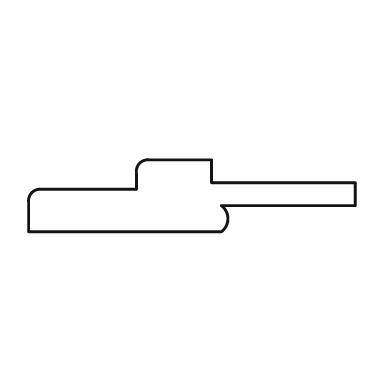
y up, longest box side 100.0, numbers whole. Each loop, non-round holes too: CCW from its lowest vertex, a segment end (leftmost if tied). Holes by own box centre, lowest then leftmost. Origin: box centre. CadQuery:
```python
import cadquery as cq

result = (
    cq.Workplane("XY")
    .moveTo(-50.0, -11.0)
    .lineTo(9.0, -11.0)
    .threePointArc((11.0, -7.0), (9.0, -3.0))
    .lineTo(50.0, -3.0)
    .lineTo(50.0, 4.0)
    .lineTo(6.0, 4.0)
    .lineTo(6.0, 11.0)
    .lineTo(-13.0, 11.0)
    .threePointArc((-16.0, 10.0), (-17.0, 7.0))
    .lineTo(-17.0, 2.0)
    .lineTo(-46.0, 2.0)
    .threePointArc((-49.0, 1.0), (-50.0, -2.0))
    .close()
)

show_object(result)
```